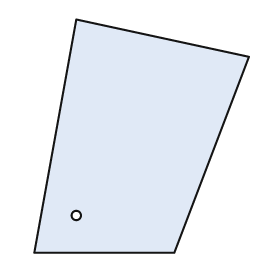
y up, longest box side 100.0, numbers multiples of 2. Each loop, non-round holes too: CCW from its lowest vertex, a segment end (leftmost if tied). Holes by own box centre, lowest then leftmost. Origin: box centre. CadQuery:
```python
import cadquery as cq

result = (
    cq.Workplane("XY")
    .moveTo(-46.0, -50.0)
    .lineTo(14.0, -50.0)
    .lineTo(46.0, 34.0)
    .lineTo(-28.0, 50.0)
    .close()
    .moveTo(-28.0, -34.0)
    .circle(2.0)
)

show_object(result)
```